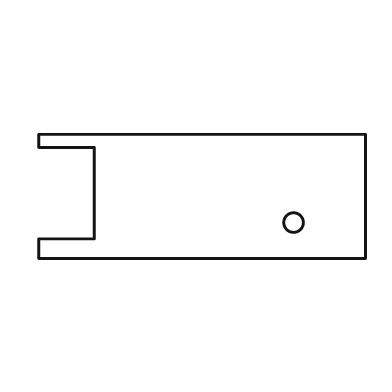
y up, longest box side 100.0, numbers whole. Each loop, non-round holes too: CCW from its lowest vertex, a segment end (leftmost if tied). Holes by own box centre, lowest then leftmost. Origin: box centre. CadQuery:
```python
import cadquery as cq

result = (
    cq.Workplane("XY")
    .moveTo(-50.0, -19.0)
    .lineTo(50.0, -19.0)
    .lineTo(50.0, 19.0)
    .lineTo(-50.0, 19.0)
    .lineTo(-50.0, 15.0)
    .lineTo(-33.0, 15.0)
    .lineTo(-33.0, -13.0)
    .lineTo(-50.0, -13.0)
    .close()
    .moveTo(28.0, -8.0)
    .circle(3.0)
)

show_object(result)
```